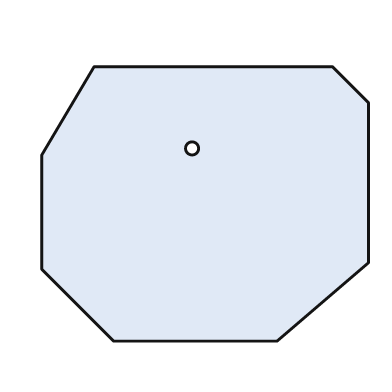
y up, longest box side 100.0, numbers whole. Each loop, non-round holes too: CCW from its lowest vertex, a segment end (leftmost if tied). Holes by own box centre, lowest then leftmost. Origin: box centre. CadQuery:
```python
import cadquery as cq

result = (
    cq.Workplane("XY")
    .moveTo(-28.0, -42.0)
    .lineTo(22.0, -42.0)
    .lineTo(50.0, -18.0)
    .lineTo(50.0, 31.0)
    .lineTo(39.0, 42.0)
    .lineTo(-34.0, 42.0)
    .lineTo(-50.0, 15.0)
    .lineTo(-50.0, -20.0)
    .close()
    .moveTo(-4.0, 17.0)
    .circle(2.0)
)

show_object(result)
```